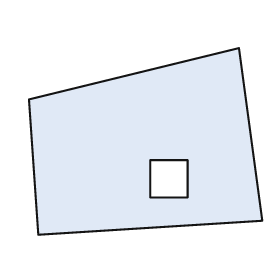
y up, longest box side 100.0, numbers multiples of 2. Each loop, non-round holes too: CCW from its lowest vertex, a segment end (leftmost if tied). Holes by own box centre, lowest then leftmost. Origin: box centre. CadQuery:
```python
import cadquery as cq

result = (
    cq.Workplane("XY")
    .moveTo(-46.0, -40.0)
    .lineTo(50.0, -34.0)
    .lineTo(40.0, 40.0)
    .lineTo(-50.0, 18.0)
    .close()
    .moveTo(2.0, -24.0)
    .lineTo(18.0, -24.0)
    .lineTo(18.0, -8.0)
    .lineTo(2.0, -8.0)
    .close()
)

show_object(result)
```